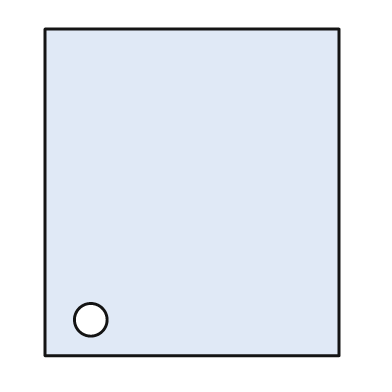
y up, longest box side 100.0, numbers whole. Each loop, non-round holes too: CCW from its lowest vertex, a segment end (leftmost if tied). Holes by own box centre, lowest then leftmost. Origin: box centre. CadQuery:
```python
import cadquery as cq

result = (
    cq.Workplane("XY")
    .moveTo(-45.0, -50.0)
    .lineTo(45.0, -50.0)
    .lineTo(45.0, 50.0)
    .lineTo(-45.0, 50.0)
    .close()
    .moveTo(-31.0, -39.0)
    .circle(5.0)
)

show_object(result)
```